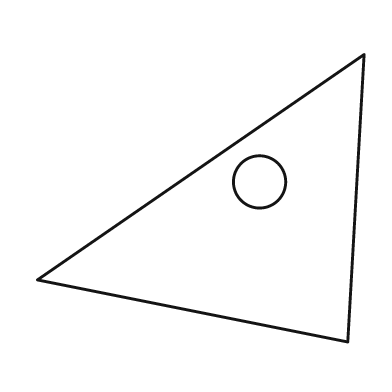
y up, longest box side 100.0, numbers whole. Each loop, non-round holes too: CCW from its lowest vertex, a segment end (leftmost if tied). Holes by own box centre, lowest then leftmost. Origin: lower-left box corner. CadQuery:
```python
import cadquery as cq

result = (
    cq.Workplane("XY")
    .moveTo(95.0, 0.0)
    .lineTo(100.0, 88.0)
    .lineTo(0.0, 19.0)
    .close()
    .moveTo(68.0, 49.0)
    .circle(8.0)
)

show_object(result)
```